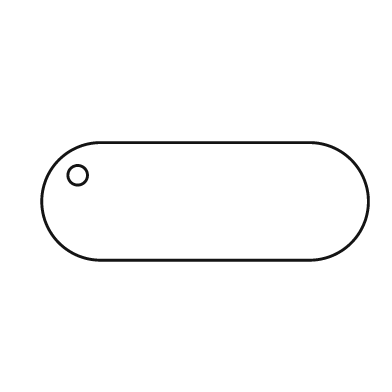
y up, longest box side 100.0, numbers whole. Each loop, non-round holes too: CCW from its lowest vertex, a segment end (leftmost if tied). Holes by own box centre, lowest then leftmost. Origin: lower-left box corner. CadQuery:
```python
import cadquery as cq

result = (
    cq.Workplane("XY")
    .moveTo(18.0, 0.0)
    .lineTo(82.0, 0.0)
    .threePointArc((100.0, 18.0), (82.0, 36.0))
    .lineTo(18.0, 36.0)
    .threePointArc((0.0, 18.0), (18.0, 0.0))
    .close()
    .moveTo(11.0, 26.0)
    .circle(3.0)
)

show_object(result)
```